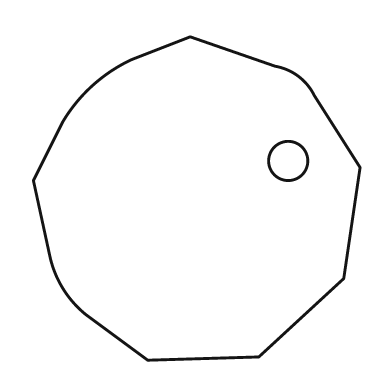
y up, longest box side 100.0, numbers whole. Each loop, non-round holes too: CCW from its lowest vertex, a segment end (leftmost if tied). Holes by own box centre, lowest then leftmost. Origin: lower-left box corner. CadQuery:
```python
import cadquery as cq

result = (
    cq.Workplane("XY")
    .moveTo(35.0, 0.0)
    .lineTo(69.0, 1.0)
    .lineTo(95.0, 25.0)
    .lineTo(100.0, 59.0)
    .lineTo(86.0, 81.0)
    .threePointArc((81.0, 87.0), (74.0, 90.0))
    .lineTo(48.0, 99.0)
    .lineTo(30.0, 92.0)
    .threePointArc((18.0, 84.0), (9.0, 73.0))
    .lineTo(0.0, 55.0)
    .lineTo(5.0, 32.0)
    .threePointArc((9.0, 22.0), (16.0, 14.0))
    .close()
    .moveTo(78.0, 61.0)
    .circle(6.0)
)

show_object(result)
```